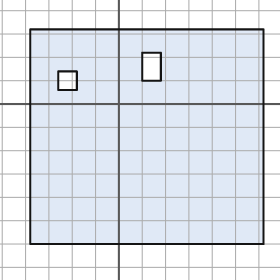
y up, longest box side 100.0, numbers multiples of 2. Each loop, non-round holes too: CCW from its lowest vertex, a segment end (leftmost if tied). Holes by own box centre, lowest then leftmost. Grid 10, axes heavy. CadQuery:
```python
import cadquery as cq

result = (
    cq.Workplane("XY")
    .moveTo(-38.0, -60.0)
    .lineTo(62.0, -60.0)
    .lineTo(62.0, 32.0)
    .lineTo(-38.0, 32.0)
    .close()
    .moveTo(-26.0, 6.0)
    .lineTo(-18.0, 6.0)
    .lineTo(-18.0, 14.0)
    .lineTo(-26.0, 14.0)
    .close()
    .moveTo(10.0, 10.0)
    .lineTo(18.0, 10.0)
    .lineTo(18.0, 22.0)
    .lineTo(10.0, 22.0)
    .close()
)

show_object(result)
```